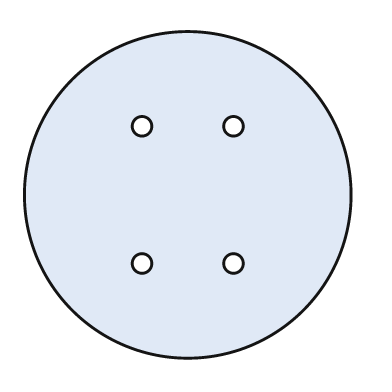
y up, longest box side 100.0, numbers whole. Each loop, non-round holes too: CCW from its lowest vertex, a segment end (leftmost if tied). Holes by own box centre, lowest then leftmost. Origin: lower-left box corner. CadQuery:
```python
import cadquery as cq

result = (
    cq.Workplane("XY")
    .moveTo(50.0, 50.0)
    .circle(50.0)
    .moveTo(36.0, 29.0)
    .circle(3.0)
    .moveTo(64.0, 29.0)
    .circle(3.0)
    .moveTo(36.0, 71.0)
    .circle(3.0)
    .moveTo(64.0, 71.0)
    .circle(3.0)
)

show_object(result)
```